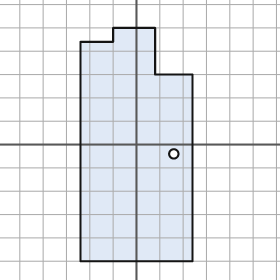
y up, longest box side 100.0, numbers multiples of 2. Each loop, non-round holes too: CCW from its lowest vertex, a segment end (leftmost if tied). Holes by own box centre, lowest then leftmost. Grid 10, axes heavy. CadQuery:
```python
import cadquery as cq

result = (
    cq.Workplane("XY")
    .moveTo(-24.0, -50.0)
    .lineTo(24.0, -50.0)
    .lineTo(24.0, 30.0)
    .lineTo(8.0, 30.0)
    .lineTo(8.0, 50.0)
    .lineTo(-10.0, 50.0)
    .lineTo(-10.0, 44.0)
    .lineTo(-24.0, 44.0)
    .close()
    .moveTo(16.0, -4.0)
    .circle(2.0)
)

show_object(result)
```